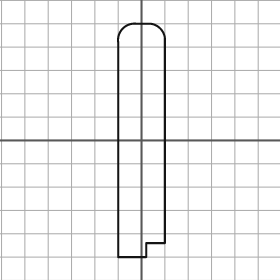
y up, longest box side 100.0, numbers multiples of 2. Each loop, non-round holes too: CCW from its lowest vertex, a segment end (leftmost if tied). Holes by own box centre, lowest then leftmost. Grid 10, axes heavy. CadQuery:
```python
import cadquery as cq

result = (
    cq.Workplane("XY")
    .moveTo(-10.0, -50.0)
    .lineTo(2.0, -50.0)
    .lineTo(2.0, -44.0)
    .lineTo(10.0, -44.0)
    .lineTo(10.0, 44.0)
    .threePointArc((8.0, 48.0), (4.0, 50.0))
    .lineTo(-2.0, 50.0)
    .threePointArc((-8.0, 48.0), (-10.0, 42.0))
    .close()
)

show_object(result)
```